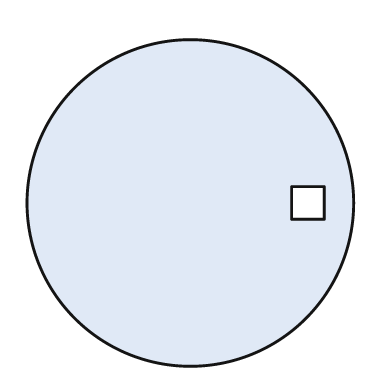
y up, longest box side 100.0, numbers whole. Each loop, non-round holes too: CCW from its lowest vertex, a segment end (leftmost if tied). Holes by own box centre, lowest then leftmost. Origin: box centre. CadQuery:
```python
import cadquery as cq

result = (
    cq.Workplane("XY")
    .moveTo(0.0, 0.0)
    .circle(50.0)
    .moveTo(31.0, -5.0)
    .lineTo(41.0, -5.0)
    .lineTo(41.0, 5.0)
    .lineTo(31.0, 5.0)
    .close()
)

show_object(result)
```